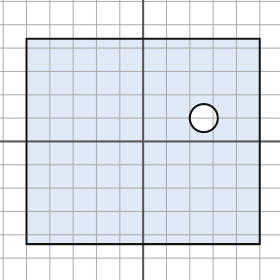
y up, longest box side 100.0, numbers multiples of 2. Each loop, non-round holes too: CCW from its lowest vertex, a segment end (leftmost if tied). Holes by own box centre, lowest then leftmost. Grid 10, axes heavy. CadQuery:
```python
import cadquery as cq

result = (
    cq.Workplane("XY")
    .moveTo(-50.0, -44.0)
    .lineTo(50.0, -44.0)
    .lineTo(50.0, 44.0)
    .lineTo(-50.0, 44.0)
    .close()
    .moveTo(26.0, 10.0)
    .circle(6.0)
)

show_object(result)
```